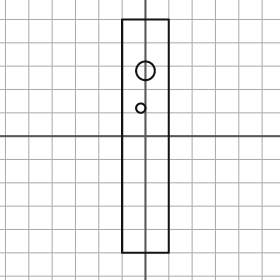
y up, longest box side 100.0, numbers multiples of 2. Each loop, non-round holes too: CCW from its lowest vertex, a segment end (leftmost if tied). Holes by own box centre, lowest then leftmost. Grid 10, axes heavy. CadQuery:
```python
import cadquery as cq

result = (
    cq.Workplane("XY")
    .moveTo(-10.0, -50.0)
    .lineTo(10.0, -50.0)
    .lineTo(10.0, 50.0)
    .lineTo(-10.0, 50.0)
    .close()
    .moveTo(-2.0, 12.0)
    .circle(2.0)
    .moveTo(0.0, 28.0)
    .circle(4.0)
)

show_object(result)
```